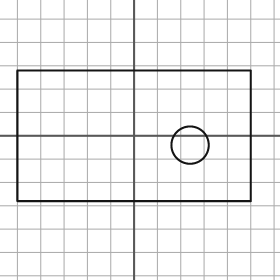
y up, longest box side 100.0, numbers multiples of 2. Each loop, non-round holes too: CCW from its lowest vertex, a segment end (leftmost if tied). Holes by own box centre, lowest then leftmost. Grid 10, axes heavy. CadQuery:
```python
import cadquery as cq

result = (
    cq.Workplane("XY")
    .moveTo(-50.0, -28.0)
    .lineTo(50.0, -28.0)
    .lineTo(50.0, 28.0)
    .lineTo(-50.0, 28.0)
    .close()
    .moveTo(24.0, -4.0)
    .circle(8.0)
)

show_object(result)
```